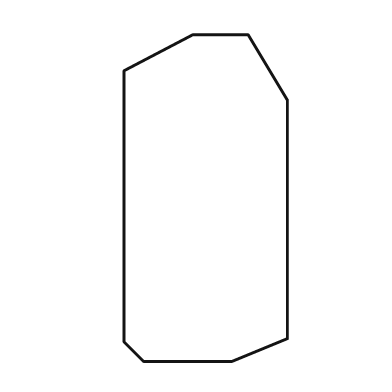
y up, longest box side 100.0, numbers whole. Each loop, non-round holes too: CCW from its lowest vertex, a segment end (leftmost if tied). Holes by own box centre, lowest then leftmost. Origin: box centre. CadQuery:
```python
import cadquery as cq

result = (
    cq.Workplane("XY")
    .moveTo(-19.0, -50.0)
    .lineTo(8.0, -50.0)
    .lineTo(25.0, -43.0)
    .lineTo(25.0, 30.0)
    .lineTo(13.0, 50.0)
    .lineTo(-4.0, 50.0)
    .lineTo(-25.0, 39.0)
    .lineTo(-25.0, -44.0)
    .close()
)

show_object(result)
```